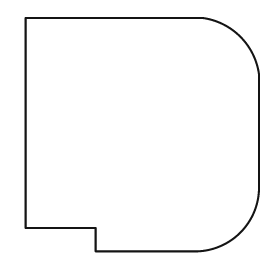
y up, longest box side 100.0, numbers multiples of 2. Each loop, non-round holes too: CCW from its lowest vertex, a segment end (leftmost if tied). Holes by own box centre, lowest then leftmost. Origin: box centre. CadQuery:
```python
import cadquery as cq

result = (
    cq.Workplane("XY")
    .moveTo(-20.0, -50.0)
    .lineTo(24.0, -50.0)
    .threePointArc((42.0, -42.0), (50.0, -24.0))
    .lineTo(50.0, 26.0)
    .threePointArc((42.0, 42.0), (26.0, 50.0))
    .lineTo(-50.0, 50.0)
    .lineTo(-50.0, -40.0)
    .lineTo(-20.0, -40.0)
    .close()
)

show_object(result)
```